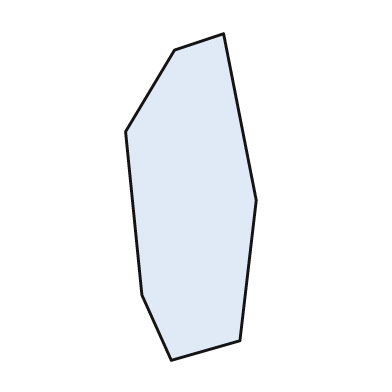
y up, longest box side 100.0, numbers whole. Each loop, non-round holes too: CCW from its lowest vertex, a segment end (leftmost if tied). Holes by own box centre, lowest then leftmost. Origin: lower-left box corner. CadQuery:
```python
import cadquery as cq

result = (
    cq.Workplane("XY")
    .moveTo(14.0, 0.0)
    .lineTo(35.0, 6.0)
    .lineTo(40.0, 49.0)
    .lineTo(30.0, 100.0)
    .lineTo(15.0, 95.0)
    .lineTo(0.0, 70.0)
    .lineTo(5.0, 20.0)
    .close()
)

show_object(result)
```